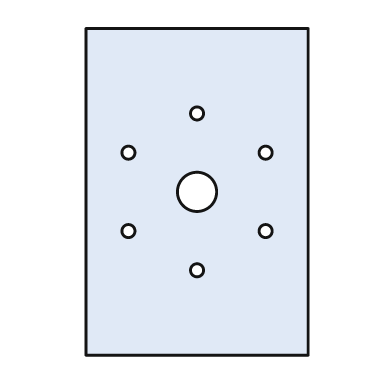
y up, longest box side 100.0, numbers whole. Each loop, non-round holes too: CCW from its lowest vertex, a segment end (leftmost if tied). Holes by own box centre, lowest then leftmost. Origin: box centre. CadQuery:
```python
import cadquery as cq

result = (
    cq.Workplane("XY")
    .moveTo(-34.0, -50.0)
    .lineTo(34.0, -50.0)
    .lineTo(34.0, 50.0)
    .lineTo(-34.0, 50.0)
    .close()
    .moveTo(0.0, -24.0)
    .circle(2.0)
    .moveTo(-21.0, -12.0)
    .circle(2.0)
    .moveTo(21.0, -12.0)
    .circle(2.0)
    .moveTo(0.0, 0.0)
    .circle(6.0)
    .moveTo(-21.0, 12.0)
    .circle(2.0)
    .moveTo(21.0, 12.0)
    .circle(2.0)
    .moveTo(0.0, 24.0)
    .circle(2.0)
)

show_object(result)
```